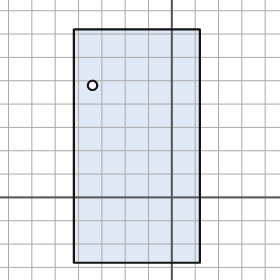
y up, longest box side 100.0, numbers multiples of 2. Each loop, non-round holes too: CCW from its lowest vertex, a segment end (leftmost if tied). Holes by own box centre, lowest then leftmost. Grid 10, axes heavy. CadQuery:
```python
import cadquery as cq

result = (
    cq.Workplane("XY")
    .moveTo(-42.0, -28.0)
    .lineTo(12.0, -28.0)
    .lineTo(12.0, 72.0)
    .lineTo(-42.0, 72.0)
    .close()
    .moveTo(-34.0, 48.0)
    .circle(2.0)
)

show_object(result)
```